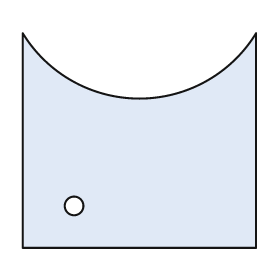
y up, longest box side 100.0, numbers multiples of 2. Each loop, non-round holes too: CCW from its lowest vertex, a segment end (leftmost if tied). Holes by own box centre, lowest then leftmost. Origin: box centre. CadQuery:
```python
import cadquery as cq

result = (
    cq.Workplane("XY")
    .moveTo(-50.0, -46.0)
    .lineTo(50.0, -46.0)
    .lineTo(50.0, 46.0)
    .threePointArc((0.0, 18.0), (-50.0, 46.0))
    .close()
    .moveTo(-28.0, -28.0)
    .circle(4.0)
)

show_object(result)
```